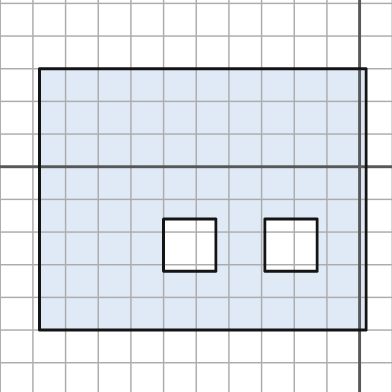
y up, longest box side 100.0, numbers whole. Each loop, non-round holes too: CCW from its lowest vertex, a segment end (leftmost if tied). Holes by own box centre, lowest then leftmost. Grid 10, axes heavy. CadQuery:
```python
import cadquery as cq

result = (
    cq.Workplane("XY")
    .moveTo(-98.0, -50.0)
    .lineTo(2.0, -50.0)
    .lineTo(2.0, 30.0)
    .lineTo(-98.0, 30.0)
    .close()
    .moveTo(-60.0, -32.0)
    .lineTo(-44.0, -32.0)
    .lineTo(-44.0, -16.0)
    .lineTo(-60.0, -16.0)
    .close()
    .moveTo(-29.0, -32.0)
    .lineTo(-13.0, -32.0)
    .lineTo(-13.0, -16.0)
    .lineTo(-29.0, -16.0)
    .close()
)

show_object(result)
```